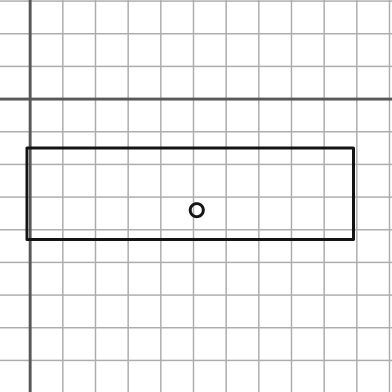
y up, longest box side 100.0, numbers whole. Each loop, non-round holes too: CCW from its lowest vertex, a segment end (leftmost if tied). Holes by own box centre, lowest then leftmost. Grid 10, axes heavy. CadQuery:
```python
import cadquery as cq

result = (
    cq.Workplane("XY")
    .moveTo(-1.0, -43.0)
    .lineTo(99.0, -43.0)
    .lineTo(99.0, -15.0)
    .lineTo(-1.0, -15.0)
    .close()
    .moveTo(51.0, -34.0)
    .circle(2.0)
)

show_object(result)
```